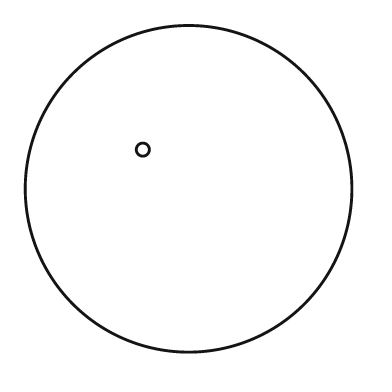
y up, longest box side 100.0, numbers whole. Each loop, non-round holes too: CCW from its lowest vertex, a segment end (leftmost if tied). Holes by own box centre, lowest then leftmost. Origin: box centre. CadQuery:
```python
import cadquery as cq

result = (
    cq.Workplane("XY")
    .moveTo(0.0, 0.0)
    .circle(50.0)
    .moveTo(-14.0, 12.0)
    .circle(2.0)
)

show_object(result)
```